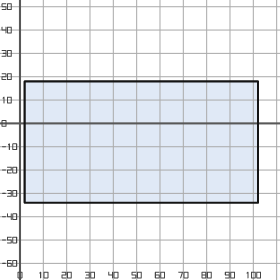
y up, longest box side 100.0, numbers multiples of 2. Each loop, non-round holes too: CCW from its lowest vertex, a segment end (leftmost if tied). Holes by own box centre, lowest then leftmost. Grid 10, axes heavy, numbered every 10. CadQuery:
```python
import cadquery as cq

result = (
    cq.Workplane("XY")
    .moveTo(2.0, -34.0)
    .lineTo(102.0, -34.0)
    .lineTo(102.0, 18.0)
    .lineTo(2.0, 18.0)
    .close()
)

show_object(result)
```